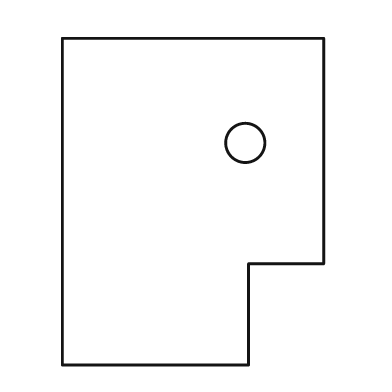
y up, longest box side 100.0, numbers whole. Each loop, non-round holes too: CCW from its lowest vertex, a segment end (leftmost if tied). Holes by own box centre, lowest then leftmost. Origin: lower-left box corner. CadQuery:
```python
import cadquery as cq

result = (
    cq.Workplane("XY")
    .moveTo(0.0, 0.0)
    .lineTo(57.0, 0.0)
    .lineTo(57.0, 31.0)
    .lineTo(80.0, 31.0)
    .lineTo(80.0, 100.0)
    .lineTo(0.0, 100.0)
    .close()
    .moveTo(56.0, 68.0)
    .circle(6.0)
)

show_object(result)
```